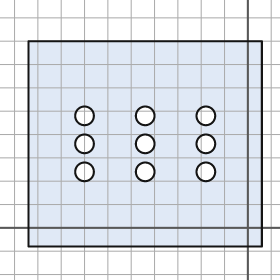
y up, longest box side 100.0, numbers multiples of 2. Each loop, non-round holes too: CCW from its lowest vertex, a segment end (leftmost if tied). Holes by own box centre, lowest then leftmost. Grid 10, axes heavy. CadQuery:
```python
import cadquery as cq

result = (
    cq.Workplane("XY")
    .moveTo(-94.0, -8.0)
    .lineTo(6.0, -8.0)
    .lineTo(6.0, 80.0)
    .lineTo(-94.0, 80.0)
    .close()
    .moveTo(-70.0, 24.0)
    .circle(4.0)
    .moveTo(-44.0, 24.0)
    .circle(4.0)
    .moveTo(-18.0, 24.0)
    .circle(4.0)
    .moveTo(-70.0, 36.0)
    .circle(4.0)
    .moveTo(-44.0, 36.0)
    .circle(4.0)
    .moveTo(-18.0, 36.0)
    .circle(4.0)
    .moveTo(-70.0, 48.0)
    .circle(4.0)
    .moveTo(-44.0, 48.0)
    .circle(4.0)
    .moveTo(-18.0, 48.0)
    .circle(4.0)
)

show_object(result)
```